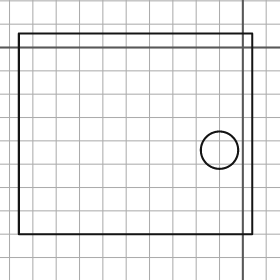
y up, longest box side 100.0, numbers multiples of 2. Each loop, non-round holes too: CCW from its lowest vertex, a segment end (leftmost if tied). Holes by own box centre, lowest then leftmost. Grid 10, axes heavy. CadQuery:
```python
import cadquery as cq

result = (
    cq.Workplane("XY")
    .moveTo(-96.0, -80.0)
    .lineTo(4.0, -80.0)
    .lineTo(4.0, 6.0)
    .lineTo(-96.0, 6.0)
    .close()
    .moveTo(-10.0, -44.0)
    .circle(8.0)
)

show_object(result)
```